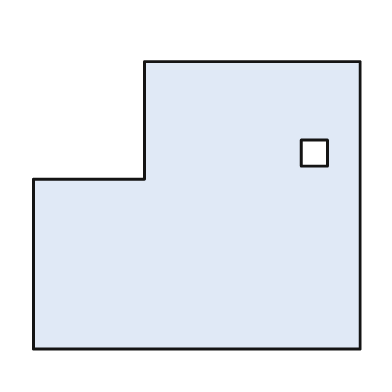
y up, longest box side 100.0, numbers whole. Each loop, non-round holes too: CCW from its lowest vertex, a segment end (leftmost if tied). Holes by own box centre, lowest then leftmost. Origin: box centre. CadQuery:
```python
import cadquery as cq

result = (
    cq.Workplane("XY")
    .moveTo(-50.0, -44.0)
    .lineTo(50.0, -44.0)
    .lineTo(50.0, 44.0)
    .lineTo(-16.0, 44.0)
    .lineTo(-16.0, 8.0)
    .lineTo(-50.0, 8.0)
    .close()
    .moveTo(32.0, 12.0)
    .lineTo(40.0, 12.0)
    .lineTo(40.0, 20.0)
    .lineTo(32.0, 20.0)
    .close()
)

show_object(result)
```